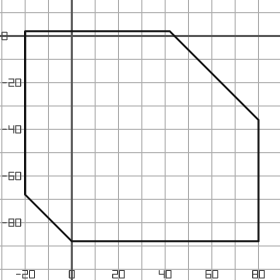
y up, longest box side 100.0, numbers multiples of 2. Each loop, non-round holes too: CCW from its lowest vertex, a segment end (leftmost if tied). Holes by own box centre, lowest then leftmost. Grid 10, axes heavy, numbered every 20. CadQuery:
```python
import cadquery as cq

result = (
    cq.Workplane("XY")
    .moveTo(0.0, -88.0)
    .lineTo(80.0, -88.0)
    .lineTo(80.0, -36.0)
    .lineTo(42.0, 2.0)
    .lineTo(-20.0, 2.0)
    .lineTo(-20.0, -68.0)
    .close()
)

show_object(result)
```